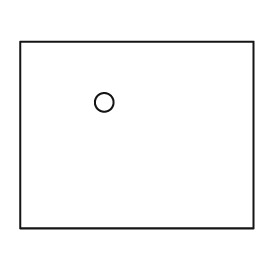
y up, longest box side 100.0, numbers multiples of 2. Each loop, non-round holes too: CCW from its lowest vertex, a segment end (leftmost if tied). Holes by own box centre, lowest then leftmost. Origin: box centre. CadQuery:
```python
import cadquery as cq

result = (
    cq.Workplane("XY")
    .moveTo(-50.0, -40.0)
    .lineTo(50.0, -40.0)
    .lineTo(50.0, 40.0)
    .lineTo(-50.0, 40.0)
    .close()
    .moveTo(-14.0, 14.0)
    .circle(4.0)
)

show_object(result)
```